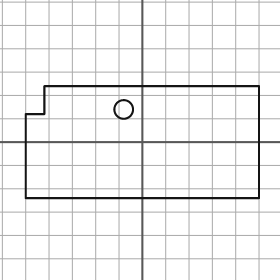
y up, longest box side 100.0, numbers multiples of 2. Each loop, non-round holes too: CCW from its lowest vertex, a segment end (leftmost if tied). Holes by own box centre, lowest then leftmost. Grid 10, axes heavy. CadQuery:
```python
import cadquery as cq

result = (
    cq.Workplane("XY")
    .moveTo(-50.0, -24.0)
    .lineTo(50.0, -24.0)
    .lineTo(50.0, 24.0)
    .lineTo(-42.0, 24.0)
    .lineTo(-42.0, 12.0)
    .lineTo(-50.0, 12.0)
    .close()
    .moveTo(-8.0, 14.0)
    .circle(4.0)
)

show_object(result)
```